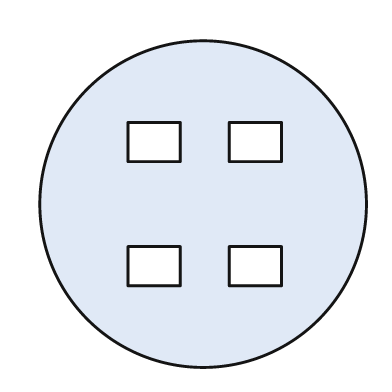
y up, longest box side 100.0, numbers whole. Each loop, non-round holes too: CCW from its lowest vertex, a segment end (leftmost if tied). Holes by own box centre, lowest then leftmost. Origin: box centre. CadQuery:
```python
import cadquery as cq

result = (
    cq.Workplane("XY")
    .moveTo(0.0, 0.0)
    .circle(50.0)
    .moveTo(-23.0, -25.0)
    .lineTo(-7.0, -25.0)
    .lineTo(-7.0, -13.0)
    .lineTo(-23.0, -13.0)
    .close()
    .moveTo(8.0, -25.0)
    .lineTo(24.0, -25.0)
    .lineTo(24.0, -13.0)
    .lineTo(8.0, -13.0)
    .close()
    .moveTo(-23.0, 13.0)
    .lineTo(-7.0, 13.0)
    .lineTo(-7.0, 25.0)
    .lineTo(-23.0, 25.0)
    .close()
    .moveTo(8.0, 13.0)
    .lineTo(24.0, 13.0)
    .lineTo(24.0, 25.0)
    .lineTo(8.0, 25.0)
    .close()
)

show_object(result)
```